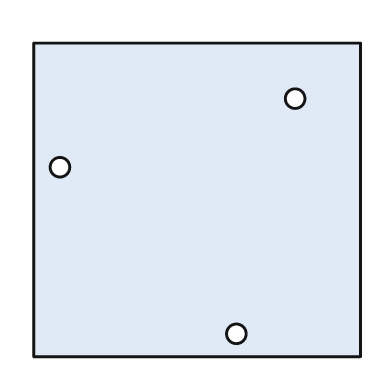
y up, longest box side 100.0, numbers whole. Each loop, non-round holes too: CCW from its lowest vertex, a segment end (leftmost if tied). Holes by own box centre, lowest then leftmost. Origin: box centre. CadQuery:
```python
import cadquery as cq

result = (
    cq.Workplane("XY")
    .moveTo(-50.0, -48.0)
    .lineTo(50.0, -48.0)
    .lineTo(50.0, 48.0)
    .lineTo(-50.0, 48.0)
    .close()
    .moveTo(12.0, -41.0)
    .circle(3.0)
    .moveTo(-42.0, 10.0)
    .circle(3.0)
    .moveTo(30.0, 31.0)
    .circle(3.0)
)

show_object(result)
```